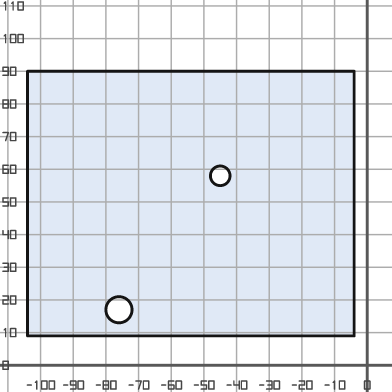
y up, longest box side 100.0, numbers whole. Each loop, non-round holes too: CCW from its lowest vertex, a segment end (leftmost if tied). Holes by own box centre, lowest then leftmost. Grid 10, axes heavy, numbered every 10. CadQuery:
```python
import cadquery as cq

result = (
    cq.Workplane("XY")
    .moveTo(-104.0, 9.0)
    .lineTo(-4.0, 9.0)
    .lineTo(-4.0, 90.0)
    .lineTo(-104.0, 90.0)
    .close()
    .moveTo(-76.0, 17.0)
    .circle(4.0)
    .moveTo(-45.0, 58.0)
    .circle(3.0)
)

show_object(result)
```